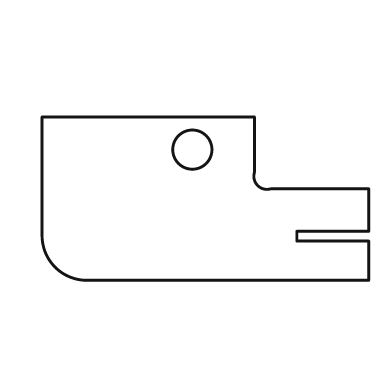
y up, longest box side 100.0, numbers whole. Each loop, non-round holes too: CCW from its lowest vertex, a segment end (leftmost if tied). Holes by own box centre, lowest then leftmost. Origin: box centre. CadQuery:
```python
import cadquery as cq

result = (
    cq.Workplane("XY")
    .moveTo(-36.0, -25.0)
    .lineTo(50.0, -25.0)
    .lineTo(50.0, -13.0)
    .lineTo(28.0, -13.0)
    .lineTo(28.0, -10.0)
    .lineTo(50.0, -10.0)
    .lineTo(50.0, 3.0)
    .lineTo(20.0, 3.0)
    .threePointArc((16.0, 4.0), (15.0, 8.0))
    .lineTo(15.0, 25.0)
    .lineTo(-50.0, 25.0)
    .lineTo(-50.0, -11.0)
    .threePointArc((-46.0, -21.0), (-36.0, -25.0))
    .close()
    .moveTo(-4.0, 15.0)
    .circle(6.0)
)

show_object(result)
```